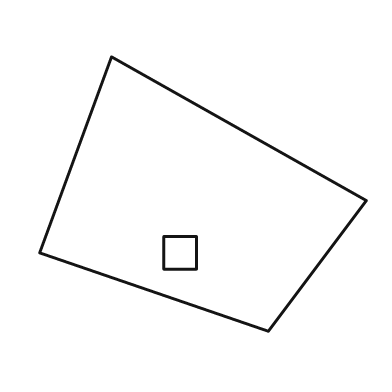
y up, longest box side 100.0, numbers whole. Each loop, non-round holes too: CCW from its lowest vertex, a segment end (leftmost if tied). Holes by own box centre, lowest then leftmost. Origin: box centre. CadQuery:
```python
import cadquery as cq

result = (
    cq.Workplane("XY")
    .moveTo(20.0, -42.0)
    .lineTo(50.0, -2.0)
    .lineTo(-28.0, 42.0)
    .lineTo(-50.0, -18.0)
    .close()
    .moveTo(-12.0, -23.0)
    .lineTo(-2.0, -23.0)
    .lineTo(-2.0, -13.0)
    .lineTo(-12.0, -13.0)
    .close()
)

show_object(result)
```